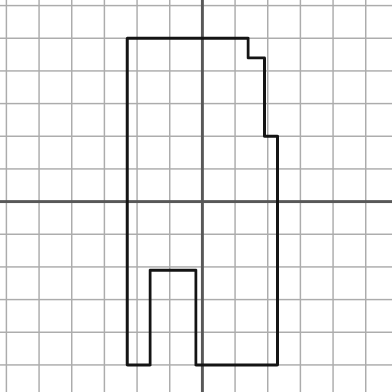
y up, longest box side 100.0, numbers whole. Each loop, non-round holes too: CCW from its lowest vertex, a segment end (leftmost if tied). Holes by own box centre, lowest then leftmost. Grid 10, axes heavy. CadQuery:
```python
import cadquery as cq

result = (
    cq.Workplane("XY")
    .moveTo(-23.0, -50.0)
    .lineTo(-16.0, -50.0)
    .lineTo(-16.0, -21.0)
    .lineTo(-2.0, -21.0)
    .lineTo(-2.0, -50.0)
    .lineTo(23.0, -50.0)
    .lineTo(23.0, 20.0)
    .lineTo(19.0, 20.0)
    .lineTo(19.0, 44.0)
    .lineTo(14.0, 44.0)
    .lineTo(14.0, 50.0)
    .lineTo(-23.0, 50.0)
    .close()
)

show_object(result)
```